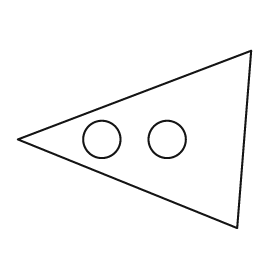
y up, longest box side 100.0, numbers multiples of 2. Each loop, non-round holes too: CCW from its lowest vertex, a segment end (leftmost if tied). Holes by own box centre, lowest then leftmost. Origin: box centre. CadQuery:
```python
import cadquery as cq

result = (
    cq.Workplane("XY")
    .moveTo(44.0, -38.0)
    .lineTo(50.0, 38.0)
    .lineTo(-50.0, 0.0)
    .close()
    .moveTo(-14.0, 0.0)
    .circle(8.0)
    .moveTo(14.0, 0.0)
    .circle(8.0)
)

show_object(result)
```